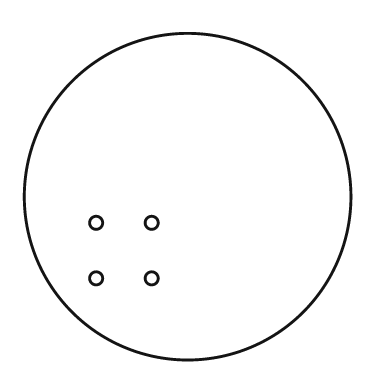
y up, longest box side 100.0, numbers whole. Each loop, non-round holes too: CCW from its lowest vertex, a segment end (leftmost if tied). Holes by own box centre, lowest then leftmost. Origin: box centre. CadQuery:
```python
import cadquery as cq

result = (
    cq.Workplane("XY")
    .moveTo(0.0, 0.0)
    .circle(50.0)
    .moveTo(-28.0, -25.0)
    .circle(2.0)
    .moveTo(-11.0, -25.0)
    .circle(2.0)
    .moveTo(-28.0, -8.0)
    .circle(2.0)
    .moveTo(-11.0, -8.0)
    .circle(2.0)
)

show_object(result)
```